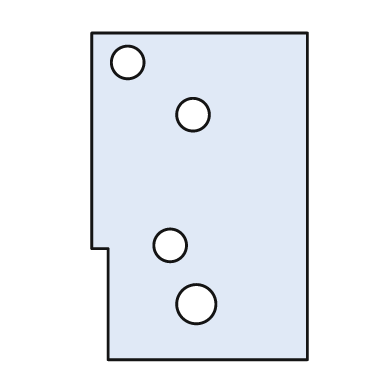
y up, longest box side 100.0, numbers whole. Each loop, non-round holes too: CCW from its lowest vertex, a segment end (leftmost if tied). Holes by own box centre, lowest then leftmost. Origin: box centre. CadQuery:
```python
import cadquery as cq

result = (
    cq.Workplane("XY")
    .moveTo(-28.0, -50.0)
    .lineTo(33.0, -50.0)
    .lineTo(33.0, 50.0)
    .lineTo(-33.0, 50.0)
    .lineTo(-33.0, -16.0)
    .lineTo(-28.0, -16.0)
    .close()
    .moveTo(-1.0, -33.0)
    .circle(6.0)
    .moveTo(-9.0, -15.0)
    .circle(5.0)
    .moveTo(-2.0, 25.0)
    .circle(5.0)
    .moveTo(-22.0, 41.0)
    .circle(5.0)
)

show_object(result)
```